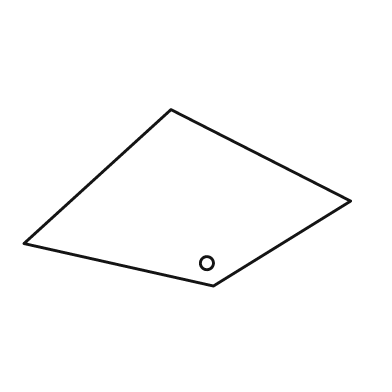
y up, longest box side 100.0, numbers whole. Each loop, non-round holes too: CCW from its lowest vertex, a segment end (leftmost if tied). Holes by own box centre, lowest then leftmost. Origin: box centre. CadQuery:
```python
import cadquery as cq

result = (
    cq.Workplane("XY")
    .moveTo(8.0, -27.0)
    .lineTo(50.0, -1.0)
    .lineTo(-5.0, 27.0)
    .lineTo(-50.0, -14.0)
    .close()
    .moveTo(6.0, -20.0)
    .circle(2.0)
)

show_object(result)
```